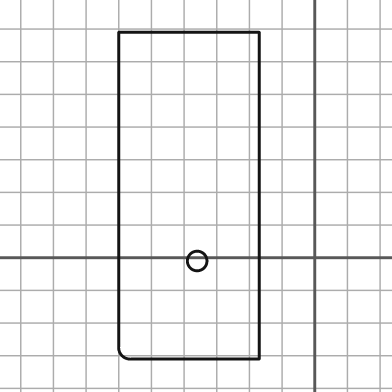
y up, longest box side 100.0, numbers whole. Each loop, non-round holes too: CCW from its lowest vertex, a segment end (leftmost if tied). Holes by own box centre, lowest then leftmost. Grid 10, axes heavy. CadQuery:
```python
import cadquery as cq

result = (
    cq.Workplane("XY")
    .moveTo(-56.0, -31.0)
    .lineTo(-17.0, -31.0)
    .lineTo(-17.0, 69.0)
    .lineTo(-60.0, 69.0)
    .lineTo(-60.0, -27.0)
    .threePointArc((-59.0, -30.0), (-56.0, -31.0))
    .close()
    .moveTo(-36.0, -1.0)
    .circle(3.0)
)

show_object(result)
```